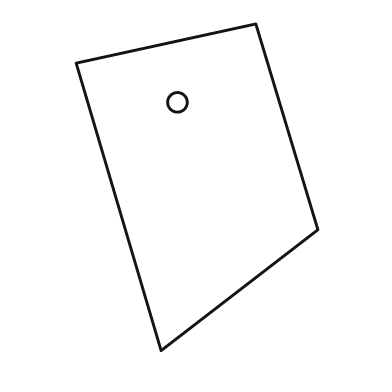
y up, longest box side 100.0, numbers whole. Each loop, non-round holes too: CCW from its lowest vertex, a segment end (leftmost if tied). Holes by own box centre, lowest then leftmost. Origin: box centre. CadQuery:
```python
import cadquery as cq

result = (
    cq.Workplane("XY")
    .moveTo(-11.0, -50.0)
    .lineTo(37.0, -13.0)
    .lineTo(18.0, 50.0)
    .lineTo(-37.0, 38.0)
    .close()
    .moveTo(-6.0, 26.0)
    .circle(3.0)
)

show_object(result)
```